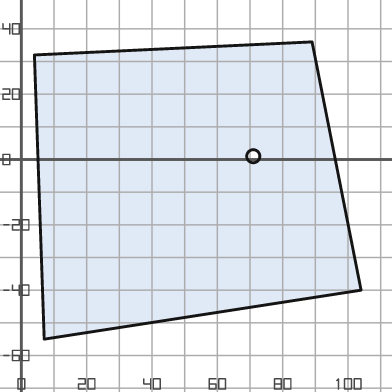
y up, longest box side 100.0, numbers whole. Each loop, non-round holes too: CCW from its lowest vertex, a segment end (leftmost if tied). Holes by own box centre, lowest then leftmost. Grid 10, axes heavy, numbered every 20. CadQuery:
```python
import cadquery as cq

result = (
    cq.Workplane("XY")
    .moveTo(7.0, -55.0)
    .lineTo(104.0, -40.0)
    .lineTo(89.0, 36.0)
    .lineTo(4.0, 32.0)
    .close()
    .moveTo(71.0, 1.0)
    .circle(2.0)
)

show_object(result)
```